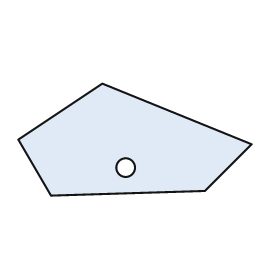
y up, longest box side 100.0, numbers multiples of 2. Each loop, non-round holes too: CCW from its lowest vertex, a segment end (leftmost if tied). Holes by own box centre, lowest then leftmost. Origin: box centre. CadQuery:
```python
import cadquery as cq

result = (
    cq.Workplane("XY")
    .moveTo(-36.0, -24.0)
    .lineTo(30.0, -22.0)
    .lineTo(50.0, -2.0)
    .lineTo(-14.0, 24.0)
    .lineTo(-50.0, 0.0)
    .close()
    .moveTo(-4.0, -12.0)
    .circle(4.0)
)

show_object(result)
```